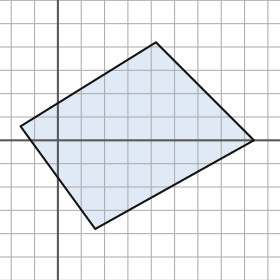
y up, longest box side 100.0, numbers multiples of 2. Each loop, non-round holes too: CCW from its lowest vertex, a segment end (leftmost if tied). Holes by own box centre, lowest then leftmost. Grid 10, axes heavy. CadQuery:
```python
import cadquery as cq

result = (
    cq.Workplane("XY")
    .moveTo(16.0, -38.0)
    .lineTo(84.0, 0.0)
    .lineTo(42.0, 42.0)
    .lineTo(-16.0, 6.0)
    .close()
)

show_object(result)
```